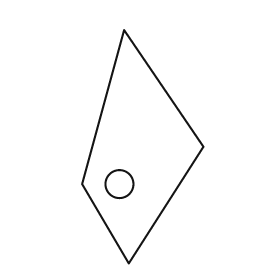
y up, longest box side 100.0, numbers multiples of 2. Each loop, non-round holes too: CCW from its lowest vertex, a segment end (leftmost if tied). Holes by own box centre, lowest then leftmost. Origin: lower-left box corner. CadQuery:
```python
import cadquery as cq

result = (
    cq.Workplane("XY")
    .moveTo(20.0, 0.0)
    .lineTo(52.0, 50.0)
    .lineTo(18.0, 100.0)
    .lineTo(0.0, 34.0)
    .close()
    .moveTo(16.0, 34.0)
    .circle(6.0)
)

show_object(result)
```